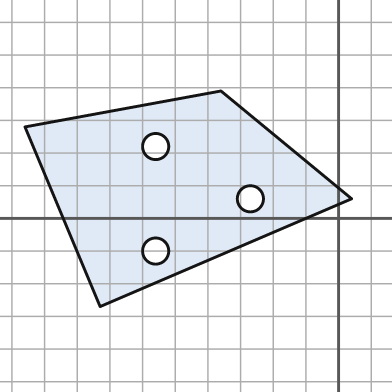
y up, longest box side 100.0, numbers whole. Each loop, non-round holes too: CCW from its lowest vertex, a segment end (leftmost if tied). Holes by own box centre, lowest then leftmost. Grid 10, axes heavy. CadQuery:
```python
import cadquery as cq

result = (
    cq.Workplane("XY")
    .moveTo(-73.0, -27.0)
    .lineTo(4.0, 6.0)
    .lineTo(-36.0, 39.0)
    .lineTo(-96.0, 28.0)
    .close()
    .moveTo(-56.0, -10.0)
    .circle(4.0)
    .moveTo(-27.0, 6.0)
    .circle(4.0)
    .moveTo(-56.0, 22.0)
    .circle(4.0)
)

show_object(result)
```